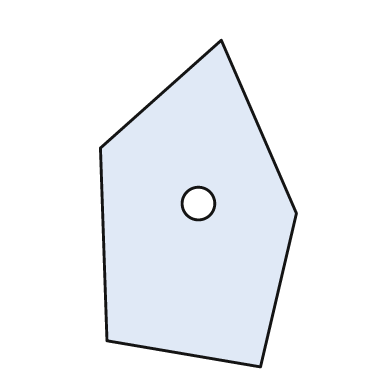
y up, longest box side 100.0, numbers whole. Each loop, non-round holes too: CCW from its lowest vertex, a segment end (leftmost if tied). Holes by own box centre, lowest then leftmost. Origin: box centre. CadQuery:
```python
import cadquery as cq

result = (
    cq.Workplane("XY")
    .moveTo(19.0, -50.0)
    .lineTo(30.0, -3.0)
    .lineTo(7.0, 50.0)
    .lineTo(-30.0, 17.0)
    .lineTo(-28.0, -42.0)
    .close()
    .moveTo(0.0, 0.0)
    .circle(5.0)
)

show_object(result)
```